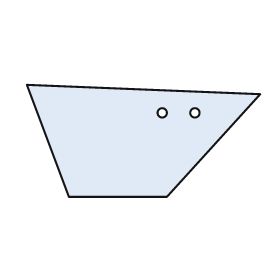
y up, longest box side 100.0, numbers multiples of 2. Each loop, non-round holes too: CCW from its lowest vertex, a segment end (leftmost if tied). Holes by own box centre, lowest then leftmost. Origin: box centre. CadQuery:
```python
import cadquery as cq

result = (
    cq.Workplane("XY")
    .moveTo(-32.0, -24.0)
    .lineTo(10.0, -24.0)
    .lineTo(50.0, 20.0)
    .lineTo(-50.0, 24.0)
    .close()
    .moveTo(8.0, 12.0)
    .circle(2.0)
    .moveTo(22.0, 12.0)
    .circle(2.0)
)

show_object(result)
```